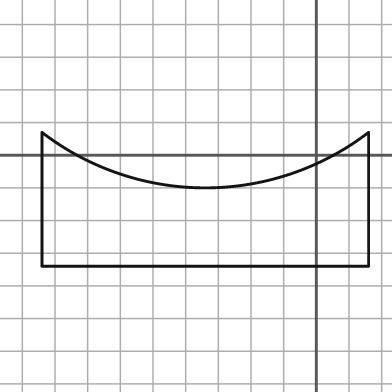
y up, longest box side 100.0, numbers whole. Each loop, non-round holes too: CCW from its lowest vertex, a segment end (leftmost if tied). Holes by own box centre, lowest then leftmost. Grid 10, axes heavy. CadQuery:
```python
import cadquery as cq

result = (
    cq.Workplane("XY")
    .moveTo(-84.0, -34.0)
    .lineTo(16.0, -34.0)
    .lineTo(16.0, 7.0)
    .threePointArc((-34.0, -10.0), (-84.0, 7.0))
    .close()
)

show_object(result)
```